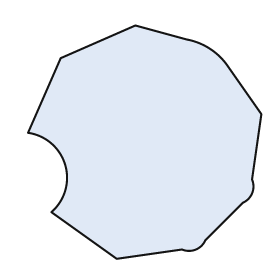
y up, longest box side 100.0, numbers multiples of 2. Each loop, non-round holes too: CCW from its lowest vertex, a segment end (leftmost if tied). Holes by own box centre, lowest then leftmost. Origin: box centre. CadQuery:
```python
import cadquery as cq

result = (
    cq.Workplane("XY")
    .moveTo(-12.0, -50.0)
    .lineTo(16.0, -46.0)
    .threePointArc((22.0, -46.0), (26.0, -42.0))
    .lineTo(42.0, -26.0)
    .threePointArc((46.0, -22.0), (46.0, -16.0))
    .lineTo(50.0, 12.0)
    .lineTo(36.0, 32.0)
    .threePointArc((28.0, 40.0), (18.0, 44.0))
    .lineTo(-4.0, 50.0)
    .lineTo(-36.0, 36.0)
    .lineTo(-50.0, 4.0)
    .threePointArc((-34.0, -10.0), (-40.0, -30.0))
    .close()
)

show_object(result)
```